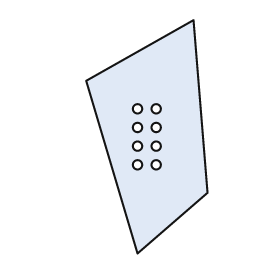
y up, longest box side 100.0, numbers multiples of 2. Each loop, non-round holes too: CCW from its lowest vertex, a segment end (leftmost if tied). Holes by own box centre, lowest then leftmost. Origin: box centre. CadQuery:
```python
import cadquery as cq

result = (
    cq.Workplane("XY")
    .moveTo(-4.0, -50.0)
    .lineTo(26.0, -24.0)
    .lineTo(20.0, 50.0)
    .lineTo(-26.0, 24.0)
    .close()
    .moveTo(-4.0, -12.0)
    .circle(2.0)
    .moveTo(4.0, -12.0)
    .circle(2.0)
    .moveTo(-4.0, -4.0)
    .circle(2.0)
    .moveTo(4.0, -4.0)
    .circle(2.0)
    .moveTo(-4.0, 4.0)
    .circle(2.0)
    .moveTo(4.0, 4.0)
    .circle(2.0)
    .moveTo(-4.0, 12.0)
    .circle(2.0)
    .moveTo(4.0, 12.0)
    .circle(2.0)
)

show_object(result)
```